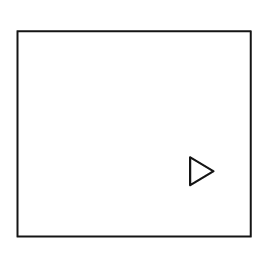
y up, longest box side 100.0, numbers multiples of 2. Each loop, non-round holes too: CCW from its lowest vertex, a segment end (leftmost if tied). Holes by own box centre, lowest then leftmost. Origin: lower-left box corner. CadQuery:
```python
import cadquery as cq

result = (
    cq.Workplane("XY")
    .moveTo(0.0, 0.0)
    .lineTo(100.0, 0.0)
    .lineTo(100.0, 88.0)
    .lineTo(0.0, 88.0)
    .close()
    .moveTo(74.0, 22.0)
    .lineTo(84.0, 28.0)
    .lineTo(74.0, 34.0)
    .close()
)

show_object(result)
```